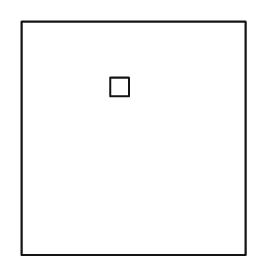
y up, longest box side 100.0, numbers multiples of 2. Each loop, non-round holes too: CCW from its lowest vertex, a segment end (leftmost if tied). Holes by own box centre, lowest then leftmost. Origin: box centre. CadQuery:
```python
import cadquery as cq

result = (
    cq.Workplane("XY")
    .moveTo(-48.0, -50.0)
    .lineTo(48.0, -50.0)
    .lineTo(48.0, 50.0)
    .lineTo(-48.0, 50.0)
    .close()
    .moveTo(-10.0, 18.0)
    .lineTo(-2.0, 18.0)
    .lineTo(-2.0, 26.0)
    .lineTo(-10.0, 26.0)
    .close()
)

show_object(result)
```